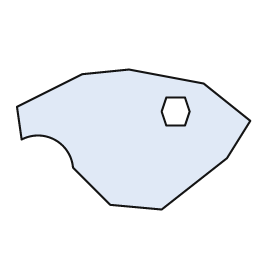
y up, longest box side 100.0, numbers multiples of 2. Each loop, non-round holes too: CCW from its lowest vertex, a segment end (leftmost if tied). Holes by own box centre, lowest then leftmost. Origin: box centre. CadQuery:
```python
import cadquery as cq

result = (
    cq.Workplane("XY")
    .moveTo(12.0, -30.0)
    .lineTo(40.0, -8.0)
    .lineTo(50.0, 8.0)
    .lineTo(30.0, 24.0)
    .lineTo(-2.0, 30.0)
    .lineTo(-22.0, 28.0)
    .lineTo(-50.0, 14.0)
    .lineTo(-48.0, 0.0)
    .threePointArc((-34.0, 0.0), (-26.0, -12.0))
    .lineTo(-10.0, -28.0)
    .close()
    .moveTo(14.0, 6.0)
    .lineTo(22.0, 6.0)
    .lineTo(24.0, 12.0)
    .lineTo(22.0, 18.0)
    .lineTo(14.0, 18.0)
    .lineTo(12.0, 12.0)
    .close()
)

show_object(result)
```